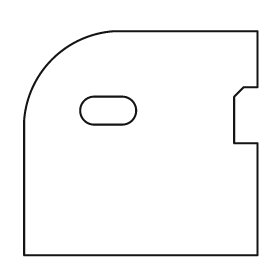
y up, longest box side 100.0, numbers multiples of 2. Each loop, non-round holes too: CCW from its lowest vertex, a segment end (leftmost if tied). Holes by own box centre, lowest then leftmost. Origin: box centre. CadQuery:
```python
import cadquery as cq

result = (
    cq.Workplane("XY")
    .moveTo(-50.0, -48.0)
    .lineTo(50.0, -48.0)
    .lineTo(50.0, 0.0)
    .lineTo(40.0, 0.0)
    .lineTo(40.0, 20.0)
    .lineTo(44.0, 24.0)
    .lineTo(50.0, 24.0)
    .lineTo(50.0, 48.0)
    .lineTo(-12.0, 48.0)
    .threePointArc((-38.0, 36.0), (-50.0, 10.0))
    .close()
    .moveTo(-20.0, 8.0)
    .lineTo(-8.0, 8.0)
    .threePointArc((-2.0, 14.0), (-8.0, 20.0))
    .lineTo(-20.0, 20.0)
    .threePointArc((-26.0, 14.0), (-20.0, 8.0))
    .close()
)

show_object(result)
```